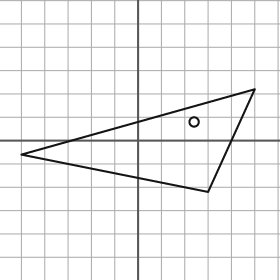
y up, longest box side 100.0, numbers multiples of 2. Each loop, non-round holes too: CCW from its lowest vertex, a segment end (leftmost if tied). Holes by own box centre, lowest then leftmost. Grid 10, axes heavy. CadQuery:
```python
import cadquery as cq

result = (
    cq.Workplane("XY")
    .moveTo(30.0, -22.0)
    .lineTo(50.0, 22.0)
    .lineTo(-50.0, -6.0)
    .close()
    .moveTo(24.0, 8.0)
    .circle(2.0)
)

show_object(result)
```